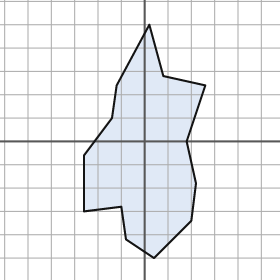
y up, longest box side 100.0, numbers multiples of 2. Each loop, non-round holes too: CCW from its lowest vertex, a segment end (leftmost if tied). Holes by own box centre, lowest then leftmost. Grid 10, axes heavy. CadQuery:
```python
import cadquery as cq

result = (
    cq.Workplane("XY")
    .moveTo(4.0, -50.0)
    .lineTo(20.0, -34.0)
    .lineTo(22.0, -18.0)
    .lineTo(18.0, 0.0)
    .lineTo(26.0, 24.0)
    .lineTo(8.0, 28.0)
    .lineTo(2.0, 50.0)
    .lineTo(-12.0, 24.0)
    .lineTo(-14.0, 10.0)
    .lineTo(-26.0, -6.0)
    .lineTo(-26.0, -30.0)
    .lineTo(-10.0, -28.0)
    .lineTo(-8.0, -42.0)
    .close()
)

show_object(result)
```